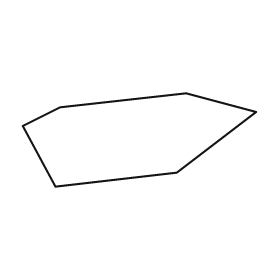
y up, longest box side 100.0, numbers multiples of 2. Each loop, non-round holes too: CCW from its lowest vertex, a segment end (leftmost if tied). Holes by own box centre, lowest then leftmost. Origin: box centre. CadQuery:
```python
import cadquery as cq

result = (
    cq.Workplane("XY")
    .moveTo(-36.0, -20.0)
    .lineTo(16.0, -14.0)
    .lineTo(50.0, 12.0)
    .lineTo(20.0, 20.0)
    .lineTo(-34.0, 14.0)
    .lineTo(-50.0, 6.0)
    .close()
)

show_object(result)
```